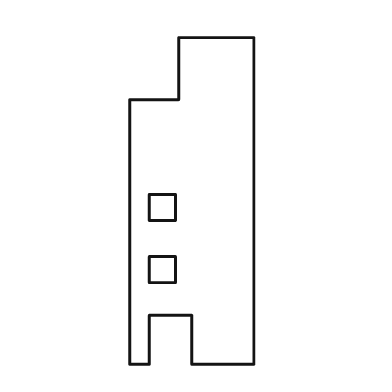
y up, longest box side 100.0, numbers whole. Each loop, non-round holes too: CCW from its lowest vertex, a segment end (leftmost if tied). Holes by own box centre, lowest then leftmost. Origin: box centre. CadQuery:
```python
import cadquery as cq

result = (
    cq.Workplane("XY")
    .moveTo(-19.0, -50.0)
    .lineTo(-13.0, -50.0)
    .lineTo(-13.0, -35.0)
    .lineTo(0.0, -35.0)
    .lineTo(0.0, -50.0)
    .lineTo(19.0, -50.0)
    .lineTo(19.0, 50.0)
    .lineTo(-4.0, 50.0)
    .lineTo(-4.0, 31.0)
    .lineTo(-19.0, 31.0)
    .close()
    .moveTo(-13.0, -25.0)
    .lineTo(-5.0, -25.0)
    .lineTo(-5.0, -17.0)
    .lineTo(-13.0, -17.0)
    .close()
    .moveTo(-13.0, -6.0)
    .lineTo(-5.0, -6.0)
    .lineTo(-5.0, 2.0)
    .lineTo(-13.0, 2.0)
    .close()
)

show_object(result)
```